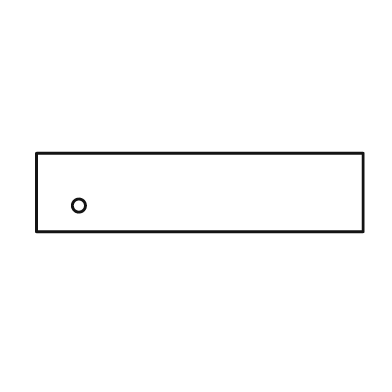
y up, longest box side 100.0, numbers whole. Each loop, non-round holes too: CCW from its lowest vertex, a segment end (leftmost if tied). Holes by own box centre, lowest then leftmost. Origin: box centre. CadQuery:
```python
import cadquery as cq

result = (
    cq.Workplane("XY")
    .moveTo(-50.0, -12.0)
    .lineTo(50.0, -12.0)
    .lineTo(50.0, 12.0)
    .lineTo(-50.0, 12.0)
    .close()
    .moveTo(-37.0, -4.0)
    .circle(2.0)
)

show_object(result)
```